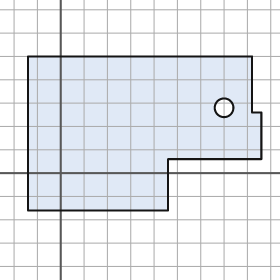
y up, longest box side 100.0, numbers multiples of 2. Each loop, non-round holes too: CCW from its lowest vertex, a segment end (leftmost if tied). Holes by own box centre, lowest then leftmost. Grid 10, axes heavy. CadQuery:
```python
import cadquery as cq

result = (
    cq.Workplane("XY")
    .moveTo(-14.0, -16.0)
    .lineTo(46.0, -16.0)
    .lineTo(46.0, 6.0)
    .lineTo(86.0, 6.0)
    .lineTo(86.0, 26.0)
    .lineTo(82.0, 26.0)
    .lineTo(82.0, 50.0)
    .lineTo(-14.0, 50.0)
    .close()
    .moveTo(70.0, 28.0)
    .circle(4.0)
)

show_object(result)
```